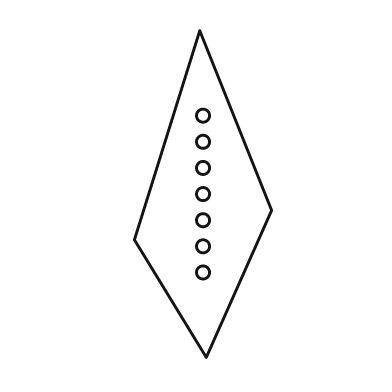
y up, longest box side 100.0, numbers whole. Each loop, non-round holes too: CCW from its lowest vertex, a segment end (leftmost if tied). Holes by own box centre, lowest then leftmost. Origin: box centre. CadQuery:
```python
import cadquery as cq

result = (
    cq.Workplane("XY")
    .moveTo(1.0, -50.0)
    .lineTo(21.0, -5.0)
    .lineTo(-1.0, 50.0)
    .lineTo(-21.0, -14.0)
    .close()
    .moveTo(0.0, -24.0)
    .circle(2.0)
    .moveTo(0.0, -16.0)
    .circle(2.0)
    .moveTo(0.0, -8.0)
    .circle(2.0)
    .moveTo(0.0, 0.0)
    .circle(2.0)
    .moveTo(0.0, 8.0)
    .circle(2.0)
    .moveTo(0.0, 16.0)
    .circle(2.0)
    .moveTo(0.0, 24.0)
    .circle(2.0)
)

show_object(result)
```